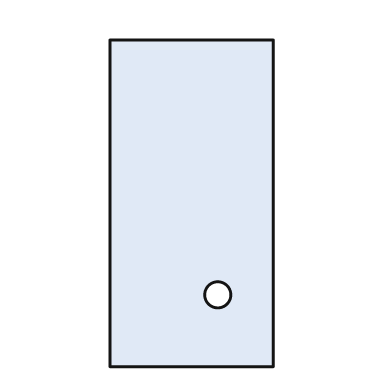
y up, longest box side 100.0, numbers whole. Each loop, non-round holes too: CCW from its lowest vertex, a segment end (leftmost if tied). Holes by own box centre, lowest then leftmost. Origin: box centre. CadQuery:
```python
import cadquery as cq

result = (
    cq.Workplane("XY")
    .moveTo(-25.0, -50.0)
    .lineTo(25.0, -50.0)
    .lineTo(25.0, 50.0)
    .lineTo(-25.0, 50.0)
    .close()
    .moveTo(8.0, -28.0)
    .circle(4.0)
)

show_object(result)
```